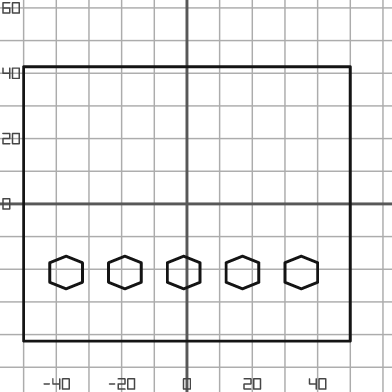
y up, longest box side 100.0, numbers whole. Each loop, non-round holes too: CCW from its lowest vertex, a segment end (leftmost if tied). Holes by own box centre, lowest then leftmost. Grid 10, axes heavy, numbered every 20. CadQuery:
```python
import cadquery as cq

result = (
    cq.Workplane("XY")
    .moveTo(-50.0, -42.0)
    .lineTo(50.0, -42.0)
    .lineTo(50.0, 42.0)
    .lineTo(-50.0, 42.0)
    .close()
    .moveTo(-37.0, -26.0)
    .lineTo(-32.0, -24.0)
    .lineTo(-32.0, -18.0)
    .lineTo(-37.0, -16.0)
    .lineTo(-42.0, -18.0)
    .lineTo(-42.0, -24.0)
    .close()
    .moveTo(-19.0, -26.0)
    .lineTo(-14.0, -24.0)
    .lineTo(-14.0, -18.0)
    .lineTo(-19.0, -16.0)
    .lineTo(-24.0, -18.0)
    .lineTo(-24.0, -24.0)
    .close()
    .moveTo(-1.0, -26.0)
    .lineTo(4.0, -24.0)
    .lineTo(4.0, -18.0)
    .lineTo(-1.0, -16.0)
    .lineTo(-6.0, -18.0)
    .lineTo(-6.0, -24.0)
    .close()
    .moveTo(17.0, -26.0)
    .lineTo(22.0, -24.0)
    .lineTo(22.0, -18.0)
    .lineTo(17.0, -16.0)
    .lineTo(12.0, -18.0)
    .lineTo(12.0, -24.0)
    .close()
    .moveTo(35.0, -26.0)
    .lineTo(40.0, -24.0)
    .lineTo(40.0, -18.0)
    .lineTo(35.0, -16.0)
    .lineTo(30.0, -18.0)
    .lineTo(30.0, -24.0)
    .close()
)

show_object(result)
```